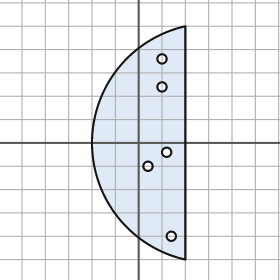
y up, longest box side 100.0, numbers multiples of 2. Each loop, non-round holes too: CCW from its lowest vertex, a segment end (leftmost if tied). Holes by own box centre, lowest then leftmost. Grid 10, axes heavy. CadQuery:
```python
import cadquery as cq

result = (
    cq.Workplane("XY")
    .moveTo(20.0, -50.0)
    .lineTo(20.0, 50.0)
    .threePointArc((-20.0, 0.0), (20.0, -50.0))
    .close()
    .moveTo(14.0, -40.0)
    .circle(2.0)
    .moveTo(4.0, -10.0)
    .circle(2.0)
    .moveTo(12.0, -4.0)
    .circle(2.0)
    .moveTo(10.0, 24.0)
    .circle(2.0)
    .moveTo(10.0, 36.0)
    .circle(2.0)
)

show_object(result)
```